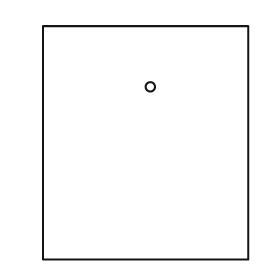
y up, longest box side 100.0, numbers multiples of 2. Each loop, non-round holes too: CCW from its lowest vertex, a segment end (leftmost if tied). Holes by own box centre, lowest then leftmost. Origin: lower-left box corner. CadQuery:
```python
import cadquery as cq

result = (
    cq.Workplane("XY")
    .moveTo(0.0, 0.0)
    .lineTo(88.0, 0.0)
    .lineTo(88.0, 100.0)
    .lineTo(0.0, 100.0)
    .close()
    .moveTo(46.0, 74.0)
    .circle(2.0)
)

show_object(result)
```